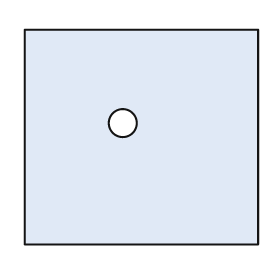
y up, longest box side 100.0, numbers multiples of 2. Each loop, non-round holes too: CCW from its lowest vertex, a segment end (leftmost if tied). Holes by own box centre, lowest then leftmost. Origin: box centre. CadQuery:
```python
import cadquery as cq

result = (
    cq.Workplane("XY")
    .moveTo(-50.0, -46.0)
    .lineTo(50.0, -46.0)
    .lineTo(50.0, 46.0)
    .lineTo(-50.0, 46.0)
    .close()
    .moveTo(-8.0, 6.0)
    .circle(6.0)
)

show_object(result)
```